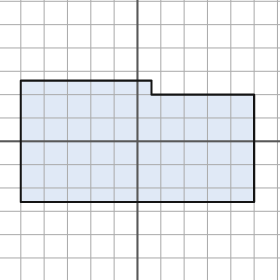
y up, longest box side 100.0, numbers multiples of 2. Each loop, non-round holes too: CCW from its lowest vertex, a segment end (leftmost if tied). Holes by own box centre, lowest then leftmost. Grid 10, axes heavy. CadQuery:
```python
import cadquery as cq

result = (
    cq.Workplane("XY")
    .moveTo(-50.0, -26.0)
    .lineTo(50.0, -26.0)
    .lineTo(50.0, 20.0)
    .lineTo(6.0, 20.0)
    .lineTo(6.0, 26.0)
    .lineTo(-50.0, 26.0)
    .close()
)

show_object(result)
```